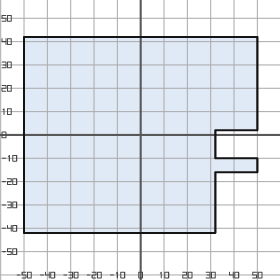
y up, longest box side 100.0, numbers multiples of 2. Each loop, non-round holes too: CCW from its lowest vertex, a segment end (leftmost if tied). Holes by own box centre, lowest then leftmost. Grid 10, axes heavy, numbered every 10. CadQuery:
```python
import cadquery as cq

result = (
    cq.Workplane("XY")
    .moveTo(-50.0, -42.0)
    .lineTo(32.0, -42.0)
    .lineTo(32.0, -16.0)
    .lineTo(50.0, -16.0)
    .lineTo(50.0, -10.0)
    .lineTo(32.0, -10.0)
    .lineTo(32.0, 2.0)
    .lineTo(50.0, 2.0)
    .lineTo(50.0, 42.0)
    .lineTo(-50.0, 42.0)
    .close()
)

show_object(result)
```